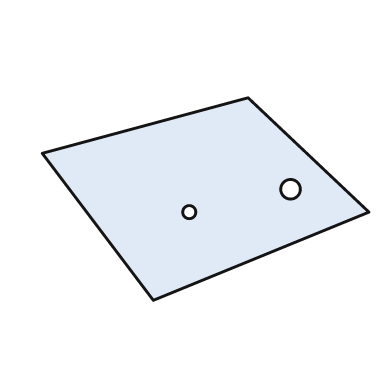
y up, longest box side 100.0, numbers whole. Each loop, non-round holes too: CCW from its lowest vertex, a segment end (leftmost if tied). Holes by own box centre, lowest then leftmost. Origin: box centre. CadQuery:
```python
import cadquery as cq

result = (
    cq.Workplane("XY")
    .moveTo(-16.0, -31.0)
    .lineTo(50.0, -4.0)
    .lineTo(13.0, 31.0)
    .lineTo(-50.0, 14.0)
    .close()
    .moveTo(-5.0, -4.0)
    .circle(2.0)
    .moveTo(26.0, 3.0)
    .circle(3.0)
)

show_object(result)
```